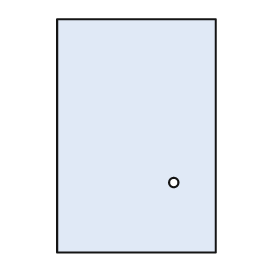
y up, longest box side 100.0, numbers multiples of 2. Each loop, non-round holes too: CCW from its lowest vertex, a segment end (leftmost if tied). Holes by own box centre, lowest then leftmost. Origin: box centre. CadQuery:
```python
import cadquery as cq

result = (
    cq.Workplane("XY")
    .moveTo(-34.0, -50.0)
    .lineTo(34.0, -50.0)
    .lineTo(34.0, 50.0)
    .lineTo(-34.0, 50.0)
    .close()
    .moveTo(16.0, -20.0)
    .circle(2.0)
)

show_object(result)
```